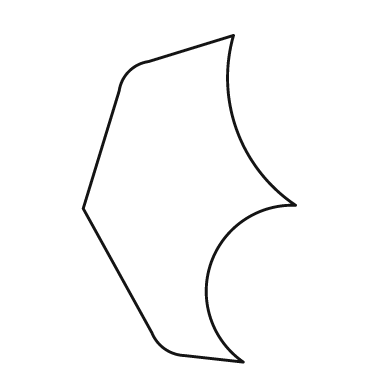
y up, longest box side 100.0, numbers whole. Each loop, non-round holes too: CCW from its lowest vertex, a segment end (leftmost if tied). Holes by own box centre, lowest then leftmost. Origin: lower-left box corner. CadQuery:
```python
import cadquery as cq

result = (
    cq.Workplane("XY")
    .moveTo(49.0, 0.0)
    .threePointArc((39.0, 30.0), (65.0, 48.0))
    .threePointArc((47.0, 71.0), (46.0, 100.0))
    .lineTo(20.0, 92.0)
    .threePointArc((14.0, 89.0), (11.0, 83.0))
    .lineTo(0.0, 47.0)
    .lineTo(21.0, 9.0)
    .threePointArc((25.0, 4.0), (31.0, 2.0))
    .close()
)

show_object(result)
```